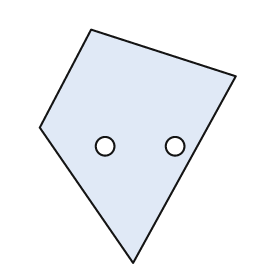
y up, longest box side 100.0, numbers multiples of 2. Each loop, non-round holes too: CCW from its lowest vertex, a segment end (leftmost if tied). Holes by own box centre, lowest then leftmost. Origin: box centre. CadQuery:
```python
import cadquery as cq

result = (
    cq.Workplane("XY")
    .moveTo(-2.0, -50.0)
    .lineTo(42.0, 30.0)
    .lineTo(-20.0, 50.0)
    .lineTo(-42.0, 8.0)
    .close()
    .moveTo(-14.0, 0.0)
    .circle(4.0)
    .moveTo(16.0, 0.0)
    .circle(4.0)
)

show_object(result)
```